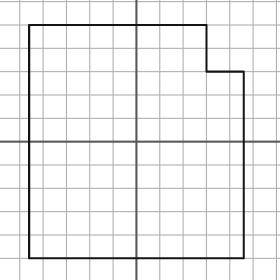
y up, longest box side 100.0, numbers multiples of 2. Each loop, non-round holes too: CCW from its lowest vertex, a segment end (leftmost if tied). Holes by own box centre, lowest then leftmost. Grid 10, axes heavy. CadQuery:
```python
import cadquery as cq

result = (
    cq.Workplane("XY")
    .moveTo(-46.0, -50.0)
    .lineTo(46.0, -50.0)
    .lineTo(46.0, 30.0)
    .lineTo(30.0, 30.0)
    .lineTo(30.0, 50.0)
    .lineTo(-46.0, 50.0)
    .close()
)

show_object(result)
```